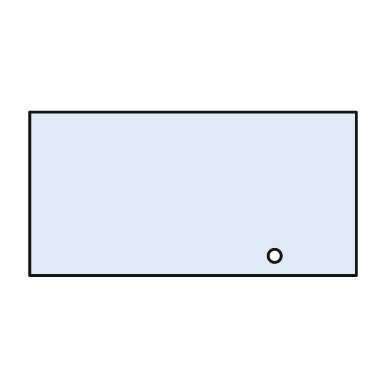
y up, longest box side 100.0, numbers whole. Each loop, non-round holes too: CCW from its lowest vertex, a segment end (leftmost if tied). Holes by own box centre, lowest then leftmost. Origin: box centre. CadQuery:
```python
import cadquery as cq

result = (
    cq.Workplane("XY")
    .moveTo(-50.0, -25.0)
    .lineTo(50.0, -25.0)
    .lineTo(50.0, 25.0)
    .lineTo(-50.0, 25.0)
    .close()
    .moveTo(25.0, -19.0)
    .circle(2.0)
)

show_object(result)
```